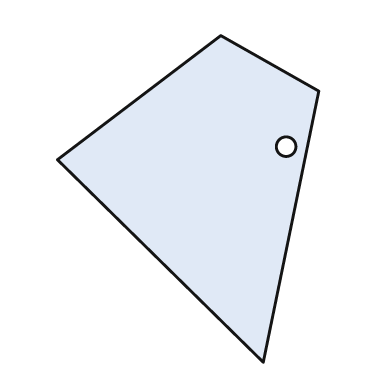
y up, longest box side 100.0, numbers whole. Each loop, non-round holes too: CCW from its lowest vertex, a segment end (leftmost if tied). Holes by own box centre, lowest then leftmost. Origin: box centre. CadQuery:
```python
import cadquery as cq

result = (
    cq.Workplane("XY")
    .moveTo(23.0, -50.0)
    .lineTo(40.0, 33.0)
    .lineTo(10.0, 50.0)
    .lineTo(-40.0, 12.0)
    .close()
    .moveTo(30.0, 16.0)
    .circle(3.0)
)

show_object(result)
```